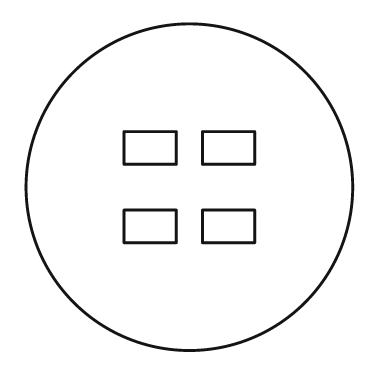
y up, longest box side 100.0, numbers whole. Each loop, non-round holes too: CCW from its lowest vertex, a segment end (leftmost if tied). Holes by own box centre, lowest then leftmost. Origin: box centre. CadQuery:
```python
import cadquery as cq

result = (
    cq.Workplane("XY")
    .moveTo(0.0, 0.0)
    .circle(50.0)
    .moveTo(-20.0, -17.0)
    .lineTo(-4.0, -17.0)
    .lineTo(-4.0, -7.0)
    .lineTo(-20.0, -7.0)
    .close()
    .moveTo(4.0, -17.0)
    .lineTo(20.0, -17.0)
    .lineTo(20.0, -7.0)
    .lineTo(4.0, -7.0)
    .close()
    .moveTo(-20.0, 7.0)
    .lineTo(-4.0, 7.0)
    .lineTo(-4.0, 17.0)
    .lineTo(-20.0, 17.0)
    .close()
    .moveTo(4.0, 7.0)
    .lineTo(20.0, 7.0)
    .lineTo(20.0, 17.0)
    .lineTo(4.0, 17.0)
    .close()
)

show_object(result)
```